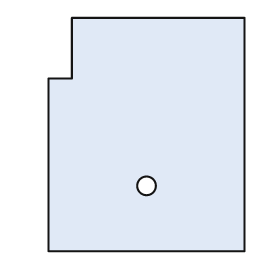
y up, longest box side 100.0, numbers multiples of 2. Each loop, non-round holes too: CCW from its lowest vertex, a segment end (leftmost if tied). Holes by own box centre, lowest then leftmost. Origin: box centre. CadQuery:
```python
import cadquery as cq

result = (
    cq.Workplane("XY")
    .moveTo(-42.0, -50.0)
    .lineTo(42.0, -50.0)
    .lineTo(42.0, 50.0)
    .lineTo(-32.0, 50.0)
    .lineTo(-32.0, 24.0)
    .lineTo(-42.0, 24.0)
    .close()
    .moveTo(0.0, -22.0)
    .circle(4.0)
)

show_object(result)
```